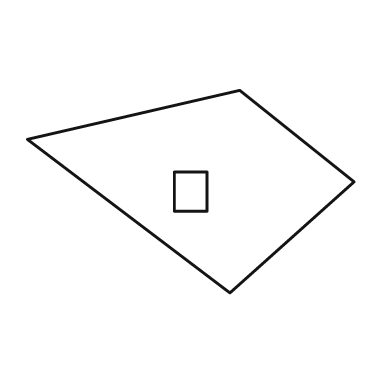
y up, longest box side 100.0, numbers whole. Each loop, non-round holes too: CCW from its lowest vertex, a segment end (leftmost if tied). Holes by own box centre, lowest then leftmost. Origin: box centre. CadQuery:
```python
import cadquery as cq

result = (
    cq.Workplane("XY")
    .moveTo(12.0, -31.0)
    .lineTo(50.0, 3.0)
    .lineTo(15.0, 31.0)
    .lineTo(-50.0, 16.0)
    .close()
    .moveTo(-5.0, -6.0)
    .lineTo(5.0, -6.0)
    .lineTo(5.0, 6.0)
    .lineTo(-5.0, 6.0)
    .close()
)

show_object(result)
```